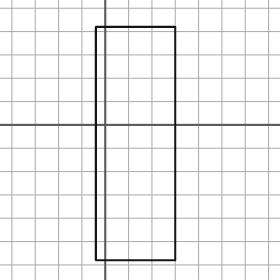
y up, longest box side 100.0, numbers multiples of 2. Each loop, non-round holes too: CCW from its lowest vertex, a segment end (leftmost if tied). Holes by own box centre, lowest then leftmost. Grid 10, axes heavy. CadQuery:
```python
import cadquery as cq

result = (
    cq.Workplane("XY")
    .moveTo(-4.0, -58.0)
    .lineTo(30.0, -58.0)
    .lineTo(30.0, 42.0)
    .lineTo(-4.0, 42.0)
    .close()
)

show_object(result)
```